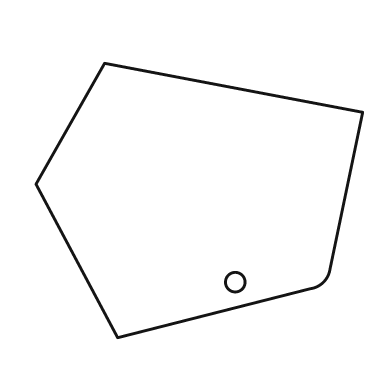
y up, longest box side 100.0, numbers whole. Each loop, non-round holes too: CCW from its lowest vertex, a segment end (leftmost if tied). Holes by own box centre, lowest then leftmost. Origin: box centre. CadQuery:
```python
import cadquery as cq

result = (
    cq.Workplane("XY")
    .moveTo(-25.0, -42.0)
    .lineTo(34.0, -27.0)
    .threePointArc((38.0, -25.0), (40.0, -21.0))
    .lineTo(50.0, 27.0)
    .lineTo(-29.0, 42.0)
    .lineTo(-50.0, 5.0)
    .close()
    .moveTo(11.0, -25.0)
    .circle(3.0)
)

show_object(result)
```